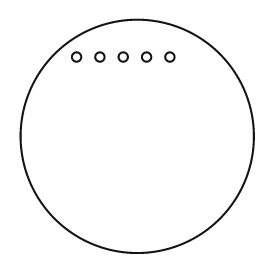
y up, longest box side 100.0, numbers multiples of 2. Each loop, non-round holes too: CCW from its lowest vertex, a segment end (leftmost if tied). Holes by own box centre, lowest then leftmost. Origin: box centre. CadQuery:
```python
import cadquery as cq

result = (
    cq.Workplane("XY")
    .moveTo(0.0, 0.0)
    .circle(50.0)
    .moveTo(-26.0, 34.0)
    .circle(2.0)
    .moveTo(-16.0, 34.0)
    .circle(2.0)
    .moveTo(-6.0, 34.0)
    .circle(2.0)
    .moveTo(4.0, 34.0)
    .circle(2.0)
    .moveTo(14.0, 34.0)
    .circle(2.0)
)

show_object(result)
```